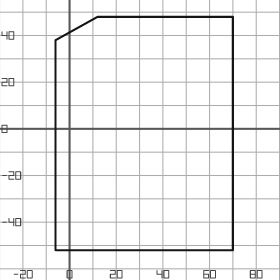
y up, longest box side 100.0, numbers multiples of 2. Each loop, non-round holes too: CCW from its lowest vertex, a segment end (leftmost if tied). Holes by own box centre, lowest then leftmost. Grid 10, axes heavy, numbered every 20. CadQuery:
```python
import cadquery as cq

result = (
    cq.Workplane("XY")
    .moveTo(-6.0, -52.0)
    .lineTo(70.0, -52.0)
    .lineTo(70.0, 48.0)
    .lineTo(12.0, 48.0)
    .lineTo(-6.0, 38.0)
    .close()
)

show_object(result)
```